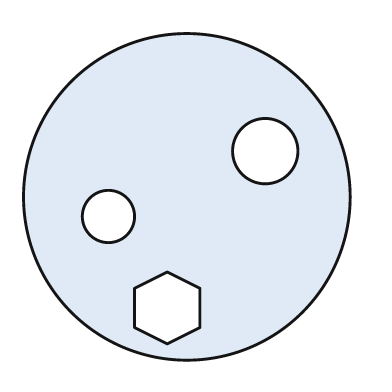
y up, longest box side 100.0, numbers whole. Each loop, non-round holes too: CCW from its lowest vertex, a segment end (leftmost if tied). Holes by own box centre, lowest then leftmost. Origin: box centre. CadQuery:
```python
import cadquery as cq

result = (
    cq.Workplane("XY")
    .moveTo(0.0, 0.0)
    .circle(50.0)
    .moveTo(-6.0, -45.0)
    .lineTo(4.0, -40.0)
    .lineTo(4.0, -28.0)
    .lineTo(-6.0, -23.0)
    .lineTo(-16.0, -28.0)
    .lineTo(-16.0, -40.0)
    .close()
    .moveTo(-24.0, -6.0)
    .circle(8.0)
    .moveTo(24.0, 14.0)
    .circle(10.0)
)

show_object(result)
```